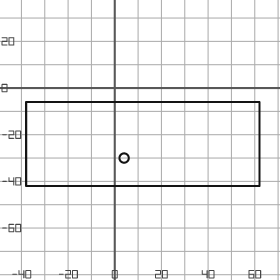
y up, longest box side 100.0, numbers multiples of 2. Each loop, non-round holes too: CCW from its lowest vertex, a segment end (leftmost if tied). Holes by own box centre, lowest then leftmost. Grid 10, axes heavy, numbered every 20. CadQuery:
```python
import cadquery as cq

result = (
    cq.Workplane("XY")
    .moveTo(-38.0, -42.0)
    .lineTo(62.0, -42.0)
    .lineTo(62.0, -6.0)
    .lineTo(-38.0, -6.0)
    .close()
    .moveTo(4.0, -30.0)
    .circle(2.0)
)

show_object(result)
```